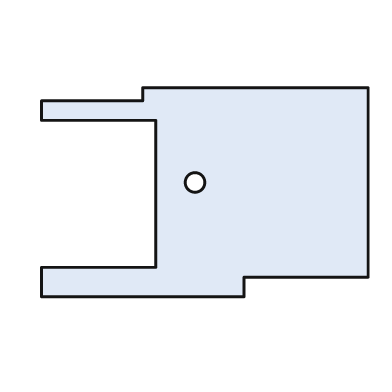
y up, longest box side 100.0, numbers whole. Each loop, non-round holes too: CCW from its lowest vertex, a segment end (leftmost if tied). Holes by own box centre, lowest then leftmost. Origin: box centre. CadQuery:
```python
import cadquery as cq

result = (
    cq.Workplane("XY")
    .moveTo(-50.0, -32.0)
    .lineTo(12.0, -32.0)
    .lineTo(12.0, -26.0)
    .lineTo(50.0, -26.0)
    .lineTo(50.0, 32.0)
    .lineTo(-19.0, 32.0)
    .lineTo(-19.0, 28.0)
    .lineTo(-50.0, 28.0)
    .lineTo(-50.0, 22.0)
    .lineTo(-15.0, 22.0)
    .lineTo(-15.0, -23.0)
    .lineTo(-50.0, -23.0)
    .close()
    .moveTo(-3.0, 3.0)
    .circle(3.0)
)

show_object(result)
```